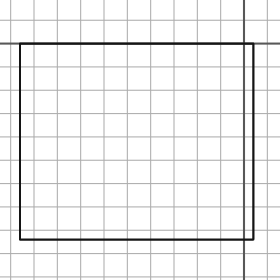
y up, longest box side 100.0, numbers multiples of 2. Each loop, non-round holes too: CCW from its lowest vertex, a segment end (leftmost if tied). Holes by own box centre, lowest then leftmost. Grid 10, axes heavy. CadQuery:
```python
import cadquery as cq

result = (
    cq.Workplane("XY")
    .moveTo(-96.0, -84.0)
    .lineTo(4.0, -84.0)
    .lineTo(4.0, 0.0)
    .lineTo(-96.0, 0.0)
    .close()
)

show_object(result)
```